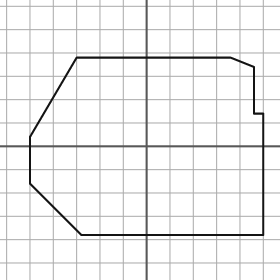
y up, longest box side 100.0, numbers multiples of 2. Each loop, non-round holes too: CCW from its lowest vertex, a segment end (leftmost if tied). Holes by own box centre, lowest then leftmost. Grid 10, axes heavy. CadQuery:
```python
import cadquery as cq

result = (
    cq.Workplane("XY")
    .moveTo(-28.0, -38.0)
    .lineTo(50.0, -38.0)
    .lineTo(50.0, 14.0)
    .lineTo(46.0, 14.0)
    .lineTo(46.0, 34.0)
    .lineTo(36.0, 38.0)
    .lineTo(-30.0, 38.0)
    .lineTo(-50.0, 4.0)
    .lineTo(-50.0, -16.0)
    .close()
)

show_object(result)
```